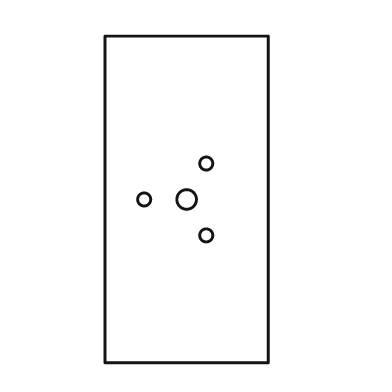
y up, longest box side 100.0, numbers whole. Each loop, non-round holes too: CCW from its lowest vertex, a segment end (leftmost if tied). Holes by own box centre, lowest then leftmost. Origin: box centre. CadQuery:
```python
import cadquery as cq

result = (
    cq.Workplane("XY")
    .moveTo(-25.0, -50.0)
    .lineTo(25.0, -50.0)
    .lineTo(25.0, 50.0)
    .lineTo(-25.0, 50.0)
    .close()
    .moveTo(6.0, -11.0)
    .circle(2.0)
    .moveTo(-13.0, 0.0)
    .circle(2.0)
    .moveTo(0.0, 0.0)
    .circle(3.0)
    .moveTo(6.0, 11.0)
    .circle(2.0)
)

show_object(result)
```